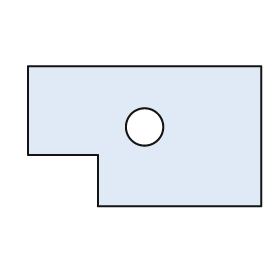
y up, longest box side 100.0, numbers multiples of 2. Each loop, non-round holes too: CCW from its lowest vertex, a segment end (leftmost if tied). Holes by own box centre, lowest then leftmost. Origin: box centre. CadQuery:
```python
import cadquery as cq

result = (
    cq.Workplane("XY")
    .moveTo(-20.0, -30.0)
    .lineTo(50.0, -30.0)
    .lineTo(50.0, 30.0)
    .lineTo(-50.0, 30.0)
    .lineTo(-50.0, -8.0)
    .lineTo(-20.0, -8.0)
    .close()
    .moveTo(0.0, 4.0)
    .circle(8.0)
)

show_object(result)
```